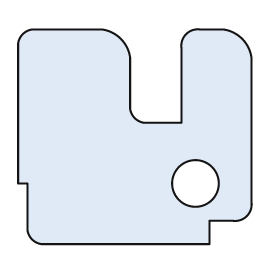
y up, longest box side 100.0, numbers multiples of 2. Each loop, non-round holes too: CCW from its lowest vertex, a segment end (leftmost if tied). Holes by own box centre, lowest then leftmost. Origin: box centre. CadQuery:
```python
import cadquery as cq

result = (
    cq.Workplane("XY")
    .moveTo(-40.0, -46.0)
    .lineTo(32.0, -46.0)
    .lineTo(32.0, -36.0)
    .lineTo(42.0, -36.0)
    .threePointArc((48.0, -34.0), (50.0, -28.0))
    .lineTo(50.0, 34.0)
    .threePointArc((46.0, 42.0), (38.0, 46.0))
    .lineTo(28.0, 46.0)
    .threePointArc((22.0, 44.0), (20.0, 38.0))
    .lineTo(20.0, 6.0)
    .lineTo(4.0, 6.0)
    .threePointArc((0.0, 8.0), (-2.0, 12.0))
    .lineTo(-2.0, 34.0)
    .threePointArc((-6.0, 42.0), (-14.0, 46.0))
    .lineTo(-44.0, 46.0)
    .threePointArc((-48.0, 44.0), (-50.0, 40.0))
    .lineTo(-50.0, -20.0)
    .lineTo(-46.0, -20.0)
    .lineTo(-46.0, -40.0)
    .threePointArc((-44.0, -44.0), (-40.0, -46.0))
    .close()
    .moveTo(26.0, -20.0)
    .circle(10.0)
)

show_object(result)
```